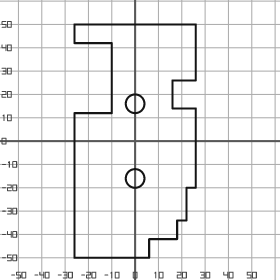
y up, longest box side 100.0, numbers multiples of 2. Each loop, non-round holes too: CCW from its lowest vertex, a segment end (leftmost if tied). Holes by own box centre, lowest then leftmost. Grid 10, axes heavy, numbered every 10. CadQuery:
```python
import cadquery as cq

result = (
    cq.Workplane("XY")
    .moveTo(-26.0, -50.0)
    .lineTo(6.0, -50.0)
    .lineTo(6.0, -42.0)
    .lineTo(18.0, -42.0)
    .lineTo(18.0, -34.0)
    .lineTo(22.0, -34.0)
    .lineTo(22.0, -20.0)
    .lineTo(26.0, -20.0)
    .lineTo(26.0, 14.0)
    .lineTo(16.0, 14.0)
    .lineTo(16.0, 26.0)
    .lineTo(26.0, 26.0)
    .lineTo(26.0, 50.0)
    .lineTo(-26.0, 50.0)
    .lineTo(-26.0, 42.0)
    .lineTo(-10.0, 42.0)
    .lineTo(-10.0, 12.0)
    .lineTo(-26.0, 12.0)
    .close()
    .moveTo(0.0, -16.0)
    .circle(4.0)
    .moveTo(0.0, 16.0)
    .circle(4.0)
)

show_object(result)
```